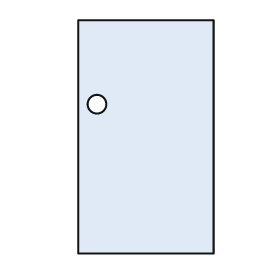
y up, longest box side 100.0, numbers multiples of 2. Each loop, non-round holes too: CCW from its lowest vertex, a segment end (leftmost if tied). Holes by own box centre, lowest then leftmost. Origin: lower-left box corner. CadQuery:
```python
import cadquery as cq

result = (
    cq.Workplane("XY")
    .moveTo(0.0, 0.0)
    .lineTo(58.0, 0.0)
    .lineTo(58.0, 100.0)
    .lineTo(0.0, 100.0)
    .close()
    .moveTo(8.0, 64.0)
    .circle(4.0)
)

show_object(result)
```